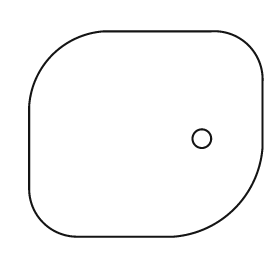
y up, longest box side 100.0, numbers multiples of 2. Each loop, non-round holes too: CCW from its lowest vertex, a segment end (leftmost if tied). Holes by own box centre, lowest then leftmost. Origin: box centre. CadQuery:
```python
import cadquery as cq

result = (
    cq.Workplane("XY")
    .moveTo(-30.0, -44.0)
    .lineTo(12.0, -44.0)
    .threePointArc((38.0, -32.0), (50.0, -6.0))
    .lineTo(50.0, 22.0)
    .threePointArc((44.0, 38.0), (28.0, 44.0))
    .lineTo(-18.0, 44.0)
    .threePointArc((-40.0, 34.0), (-50.0, 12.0))
    .lineTo(-50.0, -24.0)
    .threePointArc((-44.0, -38.0), (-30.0, -44.0))
    .close()
    .moveTo(24.0, -2.0)
    .circle(4.0)
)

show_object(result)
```